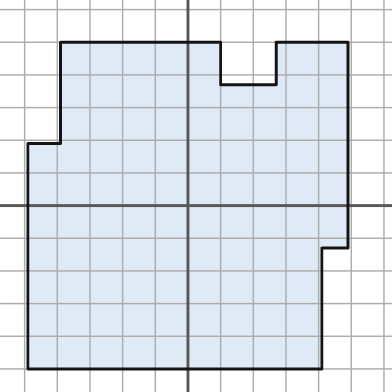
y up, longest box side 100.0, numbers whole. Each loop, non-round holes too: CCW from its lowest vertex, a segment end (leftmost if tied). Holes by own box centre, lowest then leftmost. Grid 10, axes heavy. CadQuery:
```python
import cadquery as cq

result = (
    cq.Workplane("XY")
    .moveTo(-49.0, -50.0)
    .lineTo(41.0, -50.0)
    .lineTo(41.0, -13.0)
    .lineTo(49.0, -13.0)
    .lineTo(49.0, 50.0)
    .lineTo(27.0, 50.0)
    .lineTo(27.0, 37.0)
    .lineTo(10.0, 37.0)
    .lineTo(10.0, 50.0)
    .lineTo(-39.0, 50.0)
    .lineTo(-39.0, 19.0)
    .lineTo(-49.0, 19.0)
    .close()
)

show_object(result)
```